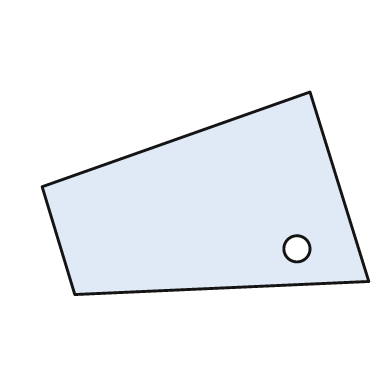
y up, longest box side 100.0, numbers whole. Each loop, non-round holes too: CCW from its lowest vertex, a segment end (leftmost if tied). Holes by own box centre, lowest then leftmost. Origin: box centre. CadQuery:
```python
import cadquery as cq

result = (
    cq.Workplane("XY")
    .moveTo(-40.0, -31.0)
    .lineTo(50.0, -27.0)
    .lineTo(32.0, 31.0)
    .lineTo(-50.0, 2.0)
    .close()
    .moveTo(28.0, -17.0)
    .circle(4.0)
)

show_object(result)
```